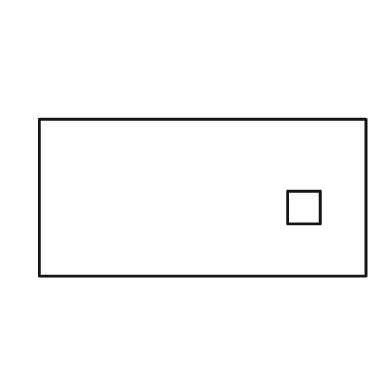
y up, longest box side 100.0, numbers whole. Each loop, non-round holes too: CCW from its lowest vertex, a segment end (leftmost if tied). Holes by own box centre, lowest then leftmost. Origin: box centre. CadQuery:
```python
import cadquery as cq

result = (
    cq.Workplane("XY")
    .moveTo(-50.0, -24.0)
    .lineTo(50.0, -24.0)
    .lineTo(50.0, 24.0)
    .lineTo(-50.0, 24.0)
    .close()
    .moveTo(26.0, -8.0)
    .lineTo(36.0, -8.0)
    .lineTo(36.0, 2.0)
    .lineTo(26.0, 2.0)
    .close()
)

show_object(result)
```